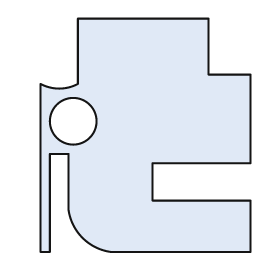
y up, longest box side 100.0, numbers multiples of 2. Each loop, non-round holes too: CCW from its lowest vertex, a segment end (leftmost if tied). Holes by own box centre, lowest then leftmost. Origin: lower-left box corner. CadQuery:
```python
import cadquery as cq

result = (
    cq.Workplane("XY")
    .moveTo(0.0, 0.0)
    .lineTo(4.0, 0.0)
    .lineTo(4.0, 42.0)
    .lineTo(12.0, 42.0)
    .lineTo(12.0, 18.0)
    .threePointArc((18.0, 6.0), (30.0, 0.0))
    .lineTo(90.0, 0.0)
    .lineTo(90.0, 22.0)
    .lineTo(48.0, 22.0)
    .lineTo(48.0, 38.0)
    .lineTo(90.0, 38.0)
    .lineTo(90.0, 76.0)
    .lineTo(72.0, 76.0)
    .lineTo(72.0, 100.0)
    .lineTo(16.0, 100.0)
    .lineTo(16.0, 72.0)
    .threePointArc((8.0, 70.0), (0.0, 72.0))
    .close()
    .moveTo(14.0, 56.0)
    .circle(10.0)
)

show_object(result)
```